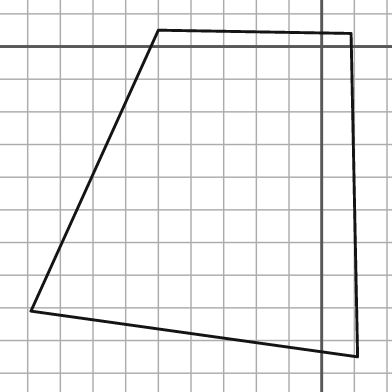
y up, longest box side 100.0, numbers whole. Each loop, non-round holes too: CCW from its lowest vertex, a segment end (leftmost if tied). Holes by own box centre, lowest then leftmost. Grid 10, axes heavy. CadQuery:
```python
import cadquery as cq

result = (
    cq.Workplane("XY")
    .moveTo(11.0, -95.0)
    .lineTo(9.0, 4.0)
    .lineTo(-50.0, 5.0)
    .lineTo(-89.0, -81.0)
    .close()
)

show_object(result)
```